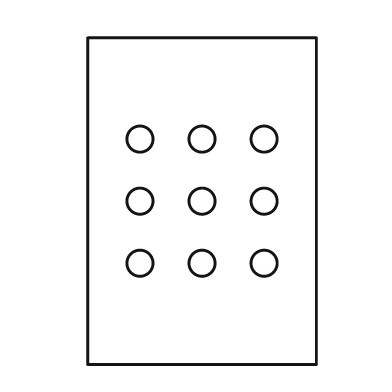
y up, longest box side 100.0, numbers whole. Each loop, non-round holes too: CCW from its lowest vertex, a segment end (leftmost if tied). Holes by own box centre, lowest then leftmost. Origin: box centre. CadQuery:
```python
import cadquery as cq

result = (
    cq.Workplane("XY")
    .moveTo(-35.0, -50.0)
    .lineTo(35.0, -50.0)
    .lineTo(35.0, 50.0)
    .lineTo(-35.0, 50.0)
    .close()
    .moveTo(-19.0, -19.0)
    .circle(4.0)
    .moveTo(0.0, -19.0)
    .circle(4.0)
    .moveTo(19.0, -19.0)
    .circle(4.0)
    .moveTo(-19.0, 0.0)
    .circle(4.0)
    .moveTo(0.0, 0.0)
    .circle(4.0)
    .moveTo(19.0, 0.0)
    .circle(4.0)
    .moveTo(-19.0, 19.0)
    .circle(4.0)
    .moveTo(0.0, 19.0)
    .circle(4.0)
    .moveTo(19.0, 19.0)
    .circle(4.0)
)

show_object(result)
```